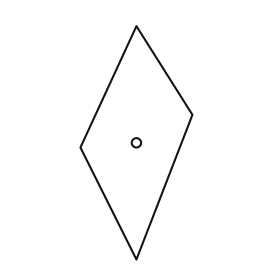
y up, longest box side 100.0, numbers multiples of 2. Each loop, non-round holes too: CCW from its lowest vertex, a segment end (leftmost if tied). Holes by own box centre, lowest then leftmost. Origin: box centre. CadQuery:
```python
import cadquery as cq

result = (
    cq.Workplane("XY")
    .moveTo(0.0, -50.0)
    .lineTo(24.0, 12.0)
    .lineTo(0.0, 50.0)
    .lineTo(-24.0, -2.0)
    .close()
    .moveTo(0.0, 0.0)
    .circle(2.0)
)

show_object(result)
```